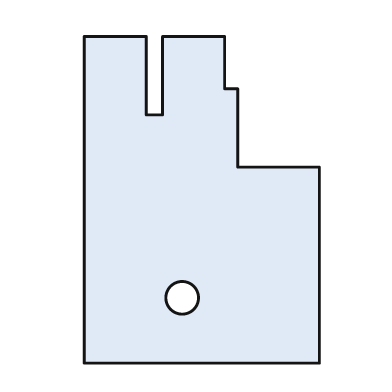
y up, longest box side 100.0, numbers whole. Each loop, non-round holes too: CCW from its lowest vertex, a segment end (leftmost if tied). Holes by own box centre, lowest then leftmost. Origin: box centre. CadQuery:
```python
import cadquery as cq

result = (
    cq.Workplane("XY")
    .moveTo(-36.0, -50.0)
    .lineTo(36.0, -50.0)
    .lineTo(36.0, 10.0)
    .lineTo(11.0, 10.0)
    .lineTo(11.0, 34.0)
    .lineTo(7.0, 34.0)
    .lineTo(7.0, 50.0)
    .lineTo(-12.0, 50.0)
    .lineTo(-12.0, 26.0)
    .lineTo(-17.0, 26.0)
    .lineTo(-17.0, 50.0)
    .lineTo(-36.0, 50.0)
    .close()
    .moveTo(-6.0, -30.0)
    .circle(5.0)
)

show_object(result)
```